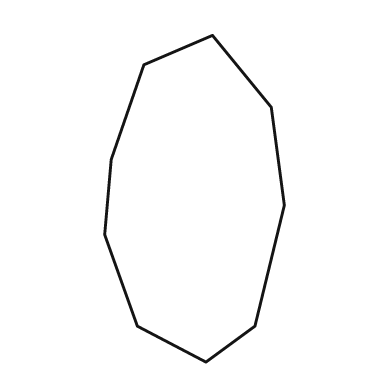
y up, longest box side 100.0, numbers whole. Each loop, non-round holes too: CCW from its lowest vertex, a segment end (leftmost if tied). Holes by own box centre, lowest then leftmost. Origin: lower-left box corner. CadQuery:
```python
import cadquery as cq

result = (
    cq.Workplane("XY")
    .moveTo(31.0, 0.0)
    .lineTo(46.0, 11.0)
    .lineTo(55.0, 48.0)
    .lineTo(51.0, 78.0)
    .lineTo(33.0, 100.0)
    .lineTo(12.0, 91.0)
    .lineTo(2.0, 62.0)
    .lineTo(0.0, 39.0)
    .lineTo(10.0, 11.0)
    .close()
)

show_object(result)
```